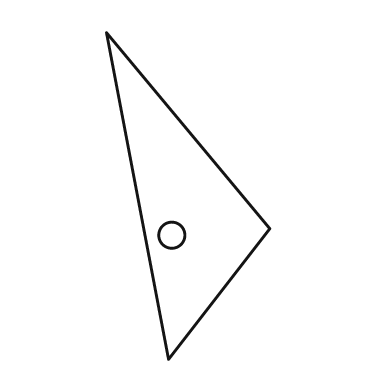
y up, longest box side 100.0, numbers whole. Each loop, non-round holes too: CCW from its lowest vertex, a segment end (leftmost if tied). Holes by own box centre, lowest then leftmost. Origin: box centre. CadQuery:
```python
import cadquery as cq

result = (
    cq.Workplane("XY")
    .moveTo(-6.0, -50.0)
    .lineTo(25.0, -10.0)
    .lineTo(-25.0, 50.0)
    .close()
    .moveTo(-5.0, -12.0)
    .circle(4.0)
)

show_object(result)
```